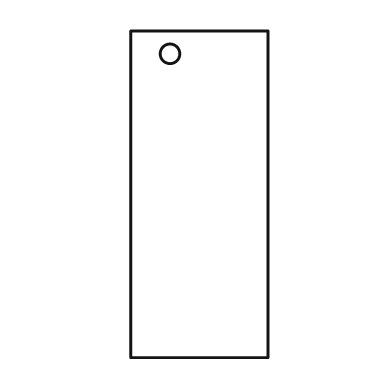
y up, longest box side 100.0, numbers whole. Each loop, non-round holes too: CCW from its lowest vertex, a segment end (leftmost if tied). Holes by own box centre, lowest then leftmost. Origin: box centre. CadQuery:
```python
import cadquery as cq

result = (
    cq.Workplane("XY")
    .moveTo(-21.0, -50.0)
    .lineTo(21.0, -50.0)
    .lineTo(21.0, 50.0)
    .lineTo(-21.0, 50.0)
    .close()
    .moveTo(-9.0, 43.0)
    .circle(3.0)
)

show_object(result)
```